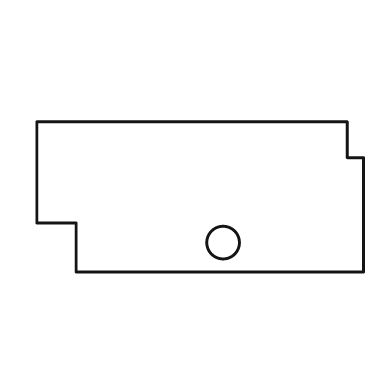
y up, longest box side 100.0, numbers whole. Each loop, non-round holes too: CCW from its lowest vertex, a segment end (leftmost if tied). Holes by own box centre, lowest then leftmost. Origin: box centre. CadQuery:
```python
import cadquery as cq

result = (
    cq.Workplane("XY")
    .moveTo(-38.0, -23.0)
    .lineTo(50.0, -23.0)
    .lineTo(50.0, 12.0)
    .lineTo(45.0, 12.0)
    .lineTo(45.0, 23.0)
    .lineTo(-50.0, 23.0)
    .lineTo(-50.0, -8.0)
    .lineTo(-38.0, -8.0)
    .close()
    .moveTo(7.0, -14.0)
    .circle(5.0)
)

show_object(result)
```